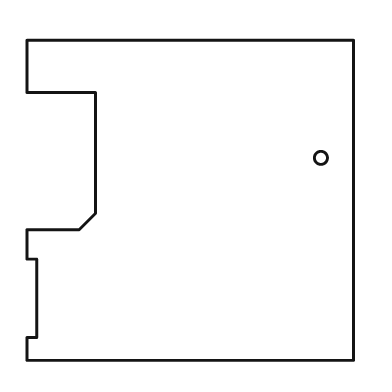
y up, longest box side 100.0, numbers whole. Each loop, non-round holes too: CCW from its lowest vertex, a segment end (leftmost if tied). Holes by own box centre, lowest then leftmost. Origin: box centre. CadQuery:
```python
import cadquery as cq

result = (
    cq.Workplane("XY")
    .moveTo(-50.0, -49.0)
    .lineTo(50.0, -49.0)
    .lineTo(50.0, 49.0)
    .lineTo(-50.0, 49.0)
    .lineTo(-50.0, 33.0)
    .lineTo(-29.0, 33.0)
    .lineTo(-29.0, -4.0)
    .lineTo(-34.0, -9.0)
    .lineTo(-50.0, -9.0)
    .lineTo(-50.0, -18.0)
    .lineTo(-47.0, -18.0)
    .lineTo(-47.0, -42.0)
    .lineTo(-50.0, -42.0)
    .close()
    .moveTo(40.0, 13.0)
    .circle(2.0)
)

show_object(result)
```